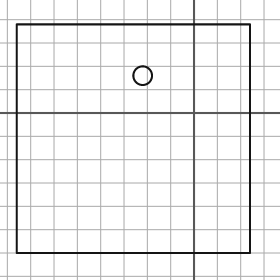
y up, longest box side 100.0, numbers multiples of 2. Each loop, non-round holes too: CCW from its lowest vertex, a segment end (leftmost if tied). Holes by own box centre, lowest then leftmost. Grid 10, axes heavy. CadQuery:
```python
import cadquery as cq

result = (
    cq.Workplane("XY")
    .moveTo(-76.0, -60.0)
    .lineTo(24.0, -60.0)
    .lineTo(24.0, 38.0)
    .lineTo(-76.0, 38.0)
    .close()
    .moveTo(-22.0, 16.0)
    .circle(4.0)
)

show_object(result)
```